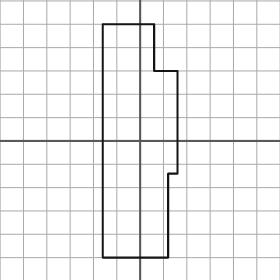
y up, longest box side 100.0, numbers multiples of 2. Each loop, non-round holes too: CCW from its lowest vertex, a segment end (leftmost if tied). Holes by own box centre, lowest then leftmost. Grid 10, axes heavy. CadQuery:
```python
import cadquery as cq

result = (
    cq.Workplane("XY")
    .moveTo(-16.0, -50.0)
    .lineTo(12.0, -50.0)
    .lineTo(12.0, -14.0)
    .lineTo(16.0, -14.0)
    .lineTo(16.0, 30.0)
    .lineTo(6.0, 30.0)
    .lineTo(6.0, 50.0)
    .lineTo(-16.0, 50.0)
    .close()
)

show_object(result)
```